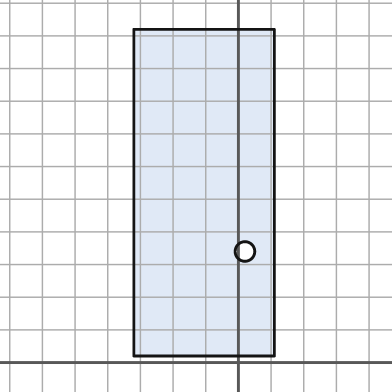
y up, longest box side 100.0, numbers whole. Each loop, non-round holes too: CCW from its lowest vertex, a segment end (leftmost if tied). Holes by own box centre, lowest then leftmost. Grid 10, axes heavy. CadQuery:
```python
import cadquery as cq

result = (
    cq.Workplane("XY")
    .moveTo(-32.0, 2.0)
    .lineTo(11.0, 2.0)
    .lineTo(11.0, 102.0)
    .lineTo(-32.0, 102.0)
    .close()
    .moveTo(2.0, 34.0)
    .circle(3.0)
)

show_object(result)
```